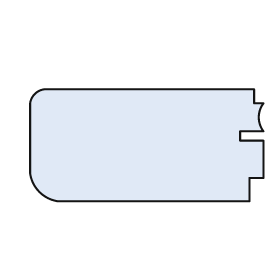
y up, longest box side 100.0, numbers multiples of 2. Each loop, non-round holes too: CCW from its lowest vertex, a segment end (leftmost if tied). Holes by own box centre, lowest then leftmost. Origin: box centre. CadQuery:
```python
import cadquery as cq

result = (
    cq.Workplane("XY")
    .moveTo(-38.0, -24.0)
    .lineTo(44.0, -24.0)
    .lineTo(44.0, -14.0)
    .lineTo(50.0, -14.0)
    .lineTo(50.0, 2.0)
    .lineTo(40.0, 2.0)
    .lineTo(40.0, 6.0)
    .lineTo(50.0, 6.0)
    .threePointArc((48.0, 12.0), (50.0, 18.0))
    .lineTo(46.0, 18.0)
    .lineTo(46.0, 24.0)
    .lineTo(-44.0, 24.0)
    .threePointArc((-48.0, 22.0), (-50.0, 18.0))
    .lineTo(-50.0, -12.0)
    .threePointArc((-46.0, -20.0), (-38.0, -24.0))
    .close()
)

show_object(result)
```